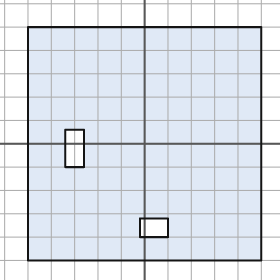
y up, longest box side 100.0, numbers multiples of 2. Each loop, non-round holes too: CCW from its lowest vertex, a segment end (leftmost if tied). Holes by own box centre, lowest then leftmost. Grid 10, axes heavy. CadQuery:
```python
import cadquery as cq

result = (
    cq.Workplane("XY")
    .moveTo(-50.0, -50.0)
    .lineTo(50.0, -50.0)
    .lineTo(50.0, 50.0)
    .lineTo(-50.0, 50.0)
    .close()
    .moveTo(-2.0, -40.0)
    .lineTo(10.0, -40.0)
    .lineTo(10.0, -32.0)
    .lineTo(-2.0, -32.0)
    .close()
    .moveTo(-34.0, -10.0)
    .lineTo(-26.0, -10.0)
    .lineTo(-26.0, 6.0)
    .lineTo(-34.0, 6.0)
    .close()
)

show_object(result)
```